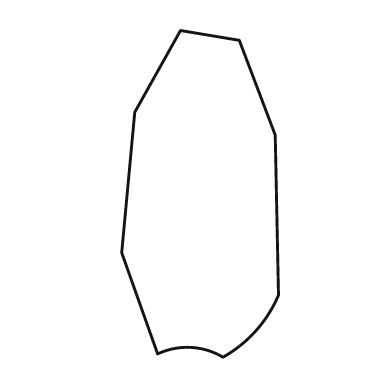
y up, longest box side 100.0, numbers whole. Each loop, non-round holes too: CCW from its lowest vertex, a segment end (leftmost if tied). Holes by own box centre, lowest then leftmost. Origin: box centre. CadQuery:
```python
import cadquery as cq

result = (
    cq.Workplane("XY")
    .moveTo(7.0, -50.0)
    .threePointArc((17.0, -42.0), (24.0, -31.0))
    .lineTo(23.0, 18.0)
    .lineTo(12.0, 47.0)
    .lineTo(-6.0, 50.0)
    .lineTo(-20.0, 25.0)
    .lineTo(-24.0, -18.0)
    .lineTo(-13.0, -49.0)
    .threePointArc((-3.0, -47.0), (7.0, -50.0))
    .close()
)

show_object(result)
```